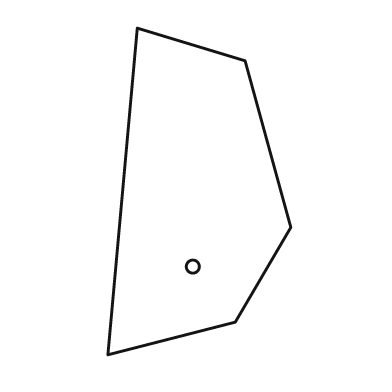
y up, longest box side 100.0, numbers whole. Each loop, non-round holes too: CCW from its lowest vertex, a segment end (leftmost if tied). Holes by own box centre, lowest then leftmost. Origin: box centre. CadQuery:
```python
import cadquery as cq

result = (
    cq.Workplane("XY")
    .moveTo(-28.0, -50.0)
    .lineTo(11.0, -40.0)
    .lineTo(28.0, -11.0)
    .lineTo(14.0, 40.0)
    .lineTo(-19.0, 50.0)
    .close()
    .moveTo(-2.0, -23.0)
    .circle(2.0)
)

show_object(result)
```